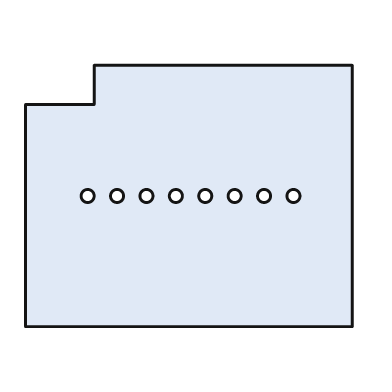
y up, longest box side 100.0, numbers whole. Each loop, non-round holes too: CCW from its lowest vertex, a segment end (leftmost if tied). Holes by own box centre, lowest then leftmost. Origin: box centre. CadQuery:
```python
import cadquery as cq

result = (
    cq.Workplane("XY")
    .moveTo(-50.0, -40.0)
    .lineTo(50.0, -40.0)
    .lineTo(50.0, 40.0)
    .lineTo(-29.0, 40.0)
    .lineTo(-29.0, 28.0)
    .lineTo(-50.0, 28.0)
    .close()
    .moveTo(-31.0, 0.0)
    .circle(2.0)
    .moveTo(-22.0, 0.0)
    .circle(2.0)
    .moveTo(-13.0, 0.0)
    .circle(2.0)
    .moveTo(-4.0, 0.0)
    .circle(2.0)
    .moveTo(5.0, 0.0)
    .circle(2.0)
    .moveTo(14.0, 0.0)
    .circle(2.0)
    .moveTo(23.0, 0.0)
    .circle(2.0)
    .moveTo(32.0, 0.0)
    .circle(2.0)
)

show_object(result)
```